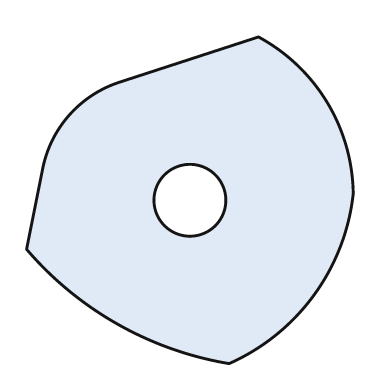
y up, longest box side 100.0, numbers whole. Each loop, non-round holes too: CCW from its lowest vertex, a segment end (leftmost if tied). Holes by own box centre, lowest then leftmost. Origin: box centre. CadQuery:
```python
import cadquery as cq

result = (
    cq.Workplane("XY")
    .moveTo(12.0, -50.0)
    .threePointArc((38.0, -29.0), (50.0, 2.0))
    .threePointArc((42.0, 30.0), (21.0, 50.0))
    .lineTo(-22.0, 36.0)
    .threePointArc((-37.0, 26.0), (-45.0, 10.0))
    .lineTo(-50.0, -15.0)
    .threePointArc((-22.0, -38.0), (12.0, -50.0))
    .close()
    .moveTo(0.0, 0.0)
    .circle(11.0)
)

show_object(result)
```